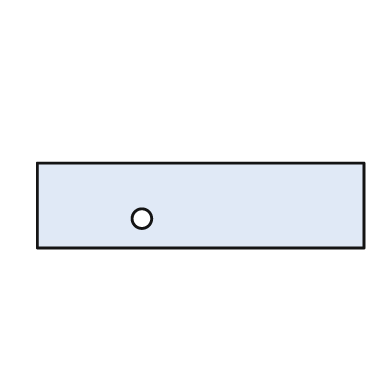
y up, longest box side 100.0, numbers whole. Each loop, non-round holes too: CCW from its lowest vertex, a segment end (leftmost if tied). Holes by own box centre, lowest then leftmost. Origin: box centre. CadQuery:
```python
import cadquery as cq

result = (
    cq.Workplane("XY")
    .moveTo(-50.0, -13.0)
    .lineTo(50.0, -13.0)
    .lineTo(50.0, 13.0)
    .lineTo(-50.0, 13.0)
    .close()
    .moveTo(-18.0, -4.0)
    .circle(3.0)
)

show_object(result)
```